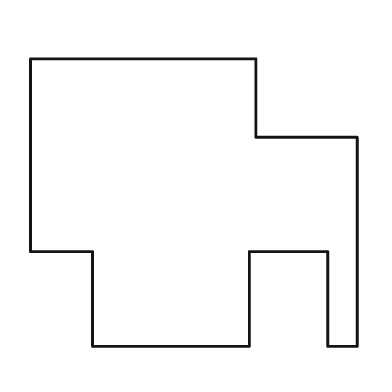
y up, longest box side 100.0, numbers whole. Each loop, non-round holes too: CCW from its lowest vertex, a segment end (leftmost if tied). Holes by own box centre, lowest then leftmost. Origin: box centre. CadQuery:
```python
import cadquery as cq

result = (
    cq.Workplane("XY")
    .moveTo(-31.0, -44.0)
    .lineTo(17.0, -44.0)
    .lineTo(17.0, -15.0)
    .lineTo(41.0, -15.0)
    .lineTo(41.0, -44.0)
    .lineTo(50.0, -44.0)
    .lineTo(50.0, 20.0)
    .lineTo(19.0, 20.0)
    .lineTo(19.0, 44.0)
    .lineTo(-50.0, 44.0)
    .lineTo(-50.0, -15.0)
    .lineTo(-31.0, -15.0)
    .close()
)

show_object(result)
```